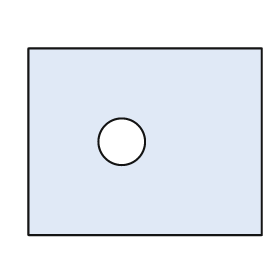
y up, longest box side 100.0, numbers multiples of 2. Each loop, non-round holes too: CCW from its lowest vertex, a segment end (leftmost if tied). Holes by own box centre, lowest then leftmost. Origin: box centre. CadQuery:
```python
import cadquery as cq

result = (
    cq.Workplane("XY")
    .moveTo(-50.0, -40.0)
    .lineTo(50.0, -40.0)
    .lineTo(50.0, 40.0)
    .lineTo(-50.0, 40.0)
    .close()
    .moveTo(-10.0, 0.0)
    .circle(10.0)
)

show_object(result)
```